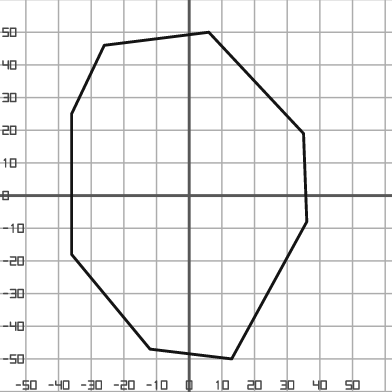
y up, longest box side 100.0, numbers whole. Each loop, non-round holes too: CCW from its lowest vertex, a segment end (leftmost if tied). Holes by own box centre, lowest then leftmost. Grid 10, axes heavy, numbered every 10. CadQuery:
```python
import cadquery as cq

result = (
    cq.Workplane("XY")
    .moveTo(13.0, -50.0)
    .lineTo(36.0, -8.0)
    .lineTo(35.0, 19.0)
    .lineTo(6.0, 50.0)
    .lineTo(-26.0, 46.0)
    .lineTo(-36.0, 25.0)
    .lineTo(-36.0, -18.0)
    .lineTo(-12.0, -47.0)
    .close()
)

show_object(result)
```